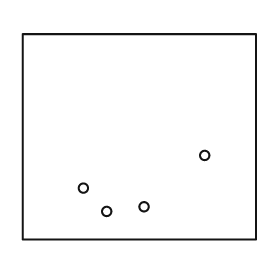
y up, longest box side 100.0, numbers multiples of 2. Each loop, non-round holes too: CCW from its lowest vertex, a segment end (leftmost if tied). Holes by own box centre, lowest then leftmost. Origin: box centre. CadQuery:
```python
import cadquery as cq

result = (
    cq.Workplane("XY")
    .moveTo(-50.0, -44.0)
    .lineTo(50.0, -44.0)
    .lineTo(50.0, 44.0)
    .lineTo(-50.0, 44.0)
    .close()
    .moveTo(-14.0, -32.0)
    .circle(2.0)
    .moveTo(2.0, -30.0)
    .circle(2.0)
    .moveTo(-24.0, -22.0)
    .circle(2.0)
    .moveTo(28.0, -8.0)
    .circle(2.0)
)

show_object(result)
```